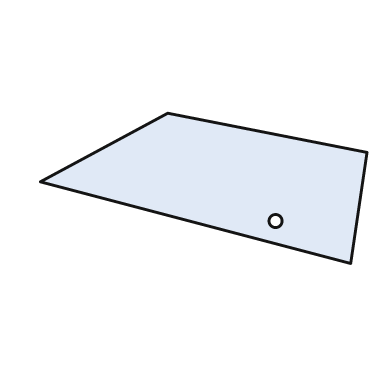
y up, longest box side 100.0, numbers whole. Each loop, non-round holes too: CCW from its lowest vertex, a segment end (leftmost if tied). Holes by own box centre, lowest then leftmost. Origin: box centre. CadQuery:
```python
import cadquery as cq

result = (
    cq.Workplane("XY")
    .moveTo(45.0, -23.0)
    .lineTo(50.0, 11.0)
    .lineTo(-11.0, 23.0)
    .lineTo(-50.0, 2.0)
    .close()
    .moveTo(22.0, -10.0)
    .circle(2.0)
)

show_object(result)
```